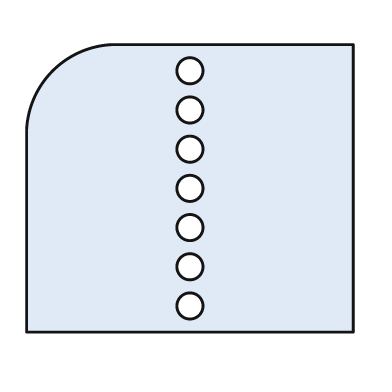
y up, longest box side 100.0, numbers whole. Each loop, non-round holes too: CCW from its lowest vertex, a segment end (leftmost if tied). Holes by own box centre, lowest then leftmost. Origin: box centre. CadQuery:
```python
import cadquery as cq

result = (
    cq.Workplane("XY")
    .moveTo(-50.0, -44.0)
    .lineTo(50.0, -44.0)
    .lineTo(50.0, 44.0)
    .lineTo(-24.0, 44.0)
    .threePointArc((-42.0, 36.0), (-50.0, 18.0))
    .close()
    .moveTo(0.0, -36.0)
    .circle(4.0)
    .moveTo(0.0, -24.0)
    .circle(4.0)
    .moveTo(0.0, -12.0)
    .circle(4.0)
    .moveTo(0.0, 0.0)
    .circle(4.0)
    .moveTo(0.0, 12.0)
    .circle(4.0)
    .moveTo(0.0, 24.0)
    .circle(4.0)
    .moveTo(0.0, 36.0)
    .circle(4.0)
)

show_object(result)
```